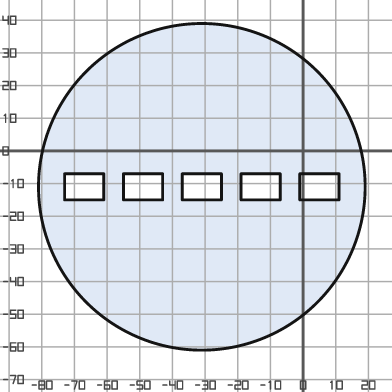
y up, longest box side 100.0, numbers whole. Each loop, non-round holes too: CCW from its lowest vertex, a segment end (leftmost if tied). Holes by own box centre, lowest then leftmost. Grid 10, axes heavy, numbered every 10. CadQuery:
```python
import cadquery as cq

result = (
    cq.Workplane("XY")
    .moveTo(-31.0, -11.0)
    .circle(50.0)
    .moveTo(-73.0, -15.0)
    .lineTo(-61.0, -15.0)
    .lineTo(-61.0, -7.0)
    .lineTo(-73.0, -7.0)
    .close()
    .moveTo(-55.0, -15.0)
    .lineTo(-43.0, -15.0)
    .lineTo(-43.0, -7.0)
    .lineTo(-55.0, -7.0)
    .close()
    .moveTo(-37.0, -15.0)
    .lineTo(-25.0, -15.0)
    .lineTo(-25.0, -7.0)
    .lineTo(-37.0, -7.0)
    .close()
    .moveTo(-19.0, -15.0)
    .lineTo(-7.0, -15.0)
    .lineTo(-7.0, -7.0)
    .lineTo(-19.0, -7.0)
    .close()
    .moveTo(-1.0, -15.0)
    .lineTo(11.0, -15.0)
    .lineTo(11.0, -7.0)
    .lineTo(-1.0, -7.0)
    .close()
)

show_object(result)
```